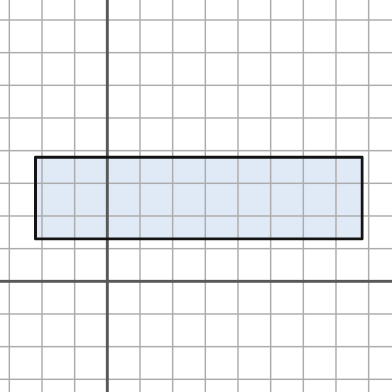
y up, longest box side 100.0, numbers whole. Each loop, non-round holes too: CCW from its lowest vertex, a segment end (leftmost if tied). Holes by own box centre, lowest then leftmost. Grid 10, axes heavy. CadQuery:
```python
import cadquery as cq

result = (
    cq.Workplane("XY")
    .moveTo(-22.0, 13.0)
    .lineTo(78.0, 13.0)
    .lineTo(78.0, 38.0)
    .lineTo(-22.0, 38.0)
    .close()
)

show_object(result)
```